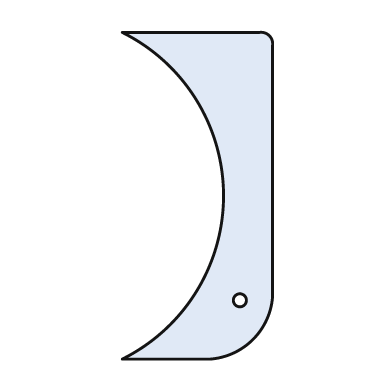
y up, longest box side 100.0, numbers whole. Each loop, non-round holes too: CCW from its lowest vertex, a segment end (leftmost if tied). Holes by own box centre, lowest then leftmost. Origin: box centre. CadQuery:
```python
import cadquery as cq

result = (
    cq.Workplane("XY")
    .moveTo(-23.0, -50.0)
    .lineTo(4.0, -50.0)
    .threePointArc((17.0, -44.0), (23.0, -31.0))
    .lineTo(23.0, 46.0)
    .threePointArc((22.0, 49.0), (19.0, 50.0))
    .lineTo(-23.0, 50.0)
    .threePointArc((8.0, 0.0), (-23.0, -50.0))
    .close()
    .moveTo(13.0, -32.0)
    .circle(2.0)
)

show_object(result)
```